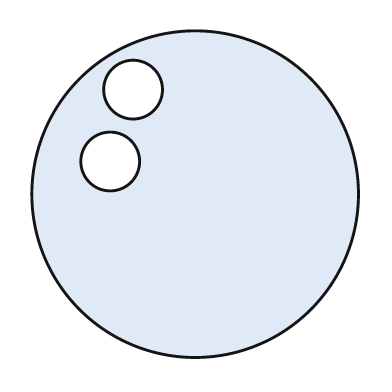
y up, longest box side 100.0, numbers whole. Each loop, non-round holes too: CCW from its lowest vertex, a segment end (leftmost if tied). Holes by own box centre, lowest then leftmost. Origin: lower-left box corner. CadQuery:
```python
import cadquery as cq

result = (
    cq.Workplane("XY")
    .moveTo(50.0, 50.0)
    .circle(50.0)
    .moveTo(24.0, 60.0)
    .circle(9.0)
    .moveTo(31.0, 82.0)
    .circle(9.0)
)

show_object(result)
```